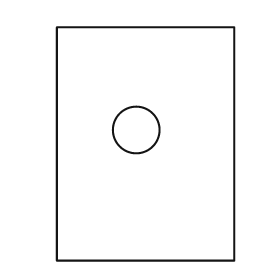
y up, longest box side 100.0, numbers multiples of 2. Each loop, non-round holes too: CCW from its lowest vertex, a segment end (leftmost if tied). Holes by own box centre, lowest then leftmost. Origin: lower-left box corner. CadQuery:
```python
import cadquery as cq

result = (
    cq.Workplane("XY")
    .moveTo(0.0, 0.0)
    .lineTo(76.0, 0.0)
    .lineTo(76.0, 100.0)
    .lineTo(0.0, 100.0)
    .close()
    .moveTo(34.0, 56.0)
    .circle(10.0)
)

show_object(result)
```